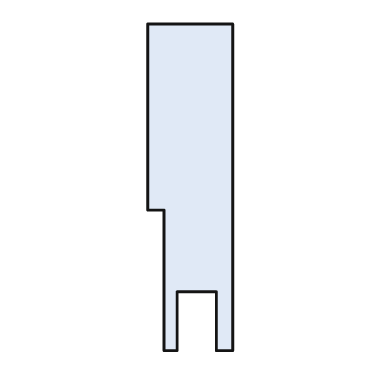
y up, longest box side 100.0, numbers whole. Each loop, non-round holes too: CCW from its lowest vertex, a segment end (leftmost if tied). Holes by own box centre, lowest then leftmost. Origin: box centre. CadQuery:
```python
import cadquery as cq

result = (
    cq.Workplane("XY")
    .moveTo(-8.0, -50.0)
    .lineTo(-4.0, -50.0)
    .lineTo(-4.0, -32.0)
    .lineTo(8.0, -32.0)
    .lineTo(8.0, -50.0)
    .lineTo(13.0, -50.0)
    .lineTo(13.0, 50.0)
    .lineTo(-13.0, 50.0)
    .lineTo(-13.0, -7.0)
    .lineTo(-8.0, -7.0)
    .close()
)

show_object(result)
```